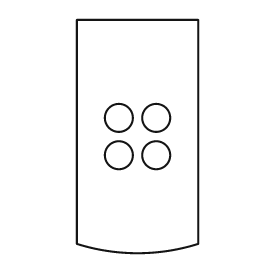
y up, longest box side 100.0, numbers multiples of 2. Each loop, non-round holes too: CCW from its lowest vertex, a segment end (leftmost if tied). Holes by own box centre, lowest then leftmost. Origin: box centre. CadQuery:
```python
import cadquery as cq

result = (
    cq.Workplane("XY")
    .moveTo(-26.0, -46.0)
    .threePointArc((0.0, -50.0), (26.0, -46.0))
    .lineTo(26.0, 50.0)
    .lineTo(-26.0, 50.0)
    .close()
    .moveTo(-8.0, -8.0)
    .circle(6.0)
    .moveTo(8.0, -8.0)
    .circle(6.0)
    .moveTo(-8.0, 8.0)
    .circle(6.0)
    .moveTo(8.0, 8.0)
    .circle(6.0)
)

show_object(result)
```